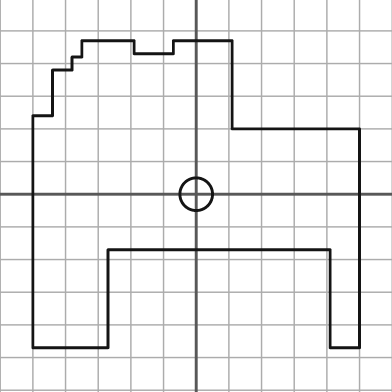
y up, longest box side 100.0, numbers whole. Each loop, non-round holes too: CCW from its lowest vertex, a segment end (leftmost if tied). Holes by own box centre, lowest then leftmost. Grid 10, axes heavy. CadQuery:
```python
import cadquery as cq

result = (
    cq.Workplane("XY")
    .moveTo(-50.0, -47.0)
    .lineTo(-27.0, -47.0)
    .lineTo(-27.0, -17.0)
    .lineTo(41.0, -17.0)
    .lineTo(41.0, -47.0)
    .lineTo(50.0, -47.0)
    .lineTo(50.0, 20.0)
    .lineTo(11.0, 20.0)
    .lineTo(11.0, 47.0)
    .lineTo(-7.0, 47.0)
    .lineTo(-7.0, 43.0)
    .lineTo(-19.0, 43.0)
    .lineTo(-19.0, 47.0)
    .lineTo(-35.0, 47.0)
    .lineTo(-35.0, 42.0)
    .lineTo(-38.0, 42.0)
    .lineTo(-38.0, 38.0)
    .lineTo(-44.0, 38.0)
    .lineTo(-44.0, 24.0)
    .lineTo(-50.0, 24.0)
    .close()
    .moveTo(0.0, 0.0)
    .circle(5.0)
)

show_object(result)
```